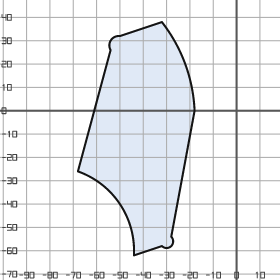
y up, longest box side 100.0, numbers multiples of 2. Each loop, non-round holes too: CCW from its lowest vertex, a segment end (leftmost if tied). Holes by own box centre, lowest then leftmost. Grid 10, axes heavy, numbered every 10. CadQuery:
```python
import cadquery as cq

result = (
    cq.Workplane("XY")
    .moveTo(-44.0, -62.0)
    .lineTo(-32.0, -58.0)
    .threePointArc((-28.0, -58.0), (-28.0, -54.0))
    .lineTo(-18.0, 0.0)
    .threePointArc((-22.0, 20.0), (-32.0, 38.0))
    .lineTo(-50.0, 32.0)
    .threePointArc((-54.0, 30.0), (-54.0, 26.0))
    .lineTo(-68.0, -26.0)
    .threePointArc((-50.0, -40.0), (-44.0, -62.0))
    .close()
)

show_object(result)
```